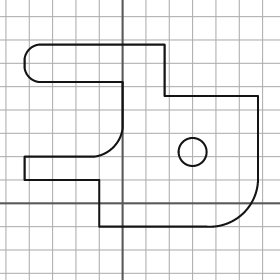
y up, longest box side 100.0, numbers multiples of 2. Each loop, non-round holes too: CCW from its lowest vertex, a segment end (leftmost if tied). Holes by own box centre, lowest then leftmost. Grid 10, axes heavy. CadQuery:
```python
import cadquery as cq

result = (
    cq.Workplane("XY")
    .moveTo(-10.0, -10.0)
    .lineTo(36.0, -10.0)
    .threePointArc((52.0, -4.0), (58.0, 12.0))
    .lineTo(58.0, 46.0)
    .lineTo(18.0, 46.0)
    .lineTo(18.0, 68.0)
    .lineTo(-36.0, 68.0)
    .threePointArc((-40.0, 66.0), (-42.0, 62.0))
    .lineTo(-42.0, 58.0)
    .threePointArc((-40.0, 54.0), (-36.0, 52.0))
    .lineTo(0.0, 52.0)
    .lineTo(0.0, 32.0)
    .threePointArc((-4.0, 24.0), (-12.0, 20.0))
    .lineTo(-42.0, 20.0)
    .lineTo(-42.0, 10.0)
    .lineTo(-10.0, 10.0)
    .close()
    .moveTo(30.0, 22.0)
    .circle(6.0)
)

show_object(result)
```